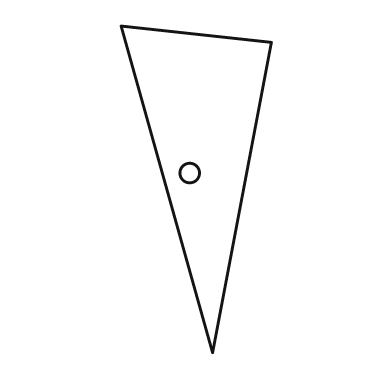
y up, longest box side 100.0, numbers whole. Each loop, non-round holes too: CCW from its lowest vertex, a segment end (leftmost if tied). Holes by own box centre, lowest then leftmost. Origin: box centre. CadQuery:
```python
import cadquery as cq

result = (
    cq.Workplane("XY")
    .moveTo(5.0, -50.0)
    .lineTo(23.0, 45.0)
    .lineTo(-23.0, 50.0)
    .close()
    .moveTo(-2.0, 5.0)
    .circle(3.0)
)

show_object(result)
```